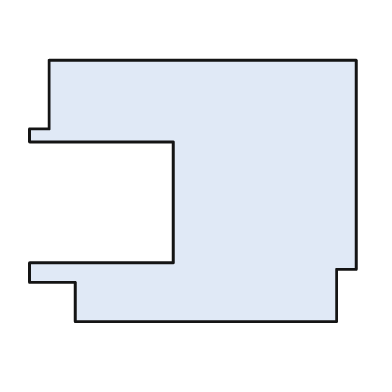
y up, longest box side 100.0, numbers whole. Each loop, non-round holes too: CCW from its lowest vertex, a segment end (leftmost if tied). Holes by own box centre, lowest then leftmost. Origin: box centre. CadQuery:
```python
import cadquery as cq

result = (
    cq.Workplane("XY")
    .moveTo(-36.0, -40.0)
    .lineTo(44.0, -40.0)
    .lineTo(44.0, -24.0)
    .lineTo(50.0, -24.0)
    .lineTo(50.0, 40.0)
    .lineTo(-44.0, 40.0)
    .lineTo(-44.0, 19.0)
    .lineTo(-50.0, 19.0)
    .lineTo(-50.0, 15.0)
    .lineTo(-6.0, 15.0)
    .lineTo(-6.0, -22.0)
    .lineTo(-50.0, -22.0)
    .lineTo(-50.0, -28.0)
    .lineTo(-36.0, -28.0)
    .close()
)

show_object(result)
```